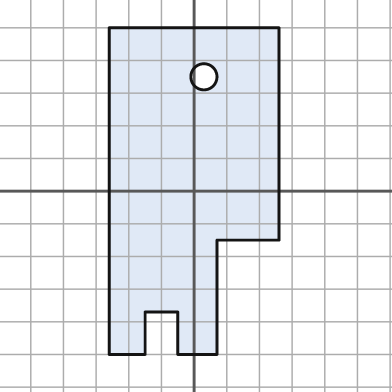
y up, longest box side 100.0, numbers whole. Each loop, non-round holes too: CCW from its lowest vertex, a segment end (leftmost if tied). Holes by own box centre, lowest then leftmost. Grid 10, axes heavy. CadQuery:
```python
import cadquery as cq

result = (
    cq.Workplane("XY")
    .moveTo(-26.0, -50.0)
    .lineTo(-15.0, -50.0)
    .lineTo(-15.0, -37.0)
    .lineTo(-5.0, -37.0)
    .lineTo(-5.0, -50.0)
    .lineTo(7.0, -50.0)
    .lineTo(7.0, -15.0)
    .lineTo(26.0, -15.0)
    .lineTo(26.0, 50.0)
    .lineTo(-26.0, 50.0)
    .close()
    .moveTo(3.0, 35.0)
    .circle(4.0)
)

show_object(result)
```